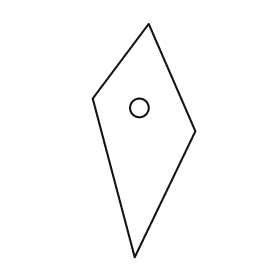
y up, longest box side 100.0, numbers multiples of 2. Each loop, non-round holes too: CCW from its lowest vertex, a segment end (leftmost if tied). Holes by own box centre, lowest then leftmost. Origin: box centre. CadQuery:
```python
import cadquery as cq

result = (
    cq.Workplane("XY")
    .moveTo(-4.0, -50.0)
    .lineTo(22.0, 4.0)
    .lineTo(2.0, 50.0)
    .lineTo(-22.0, 18.0)
    .close()
    .moveTo(-2.0, 14.0)
    .circle(4.0)
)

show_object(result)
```